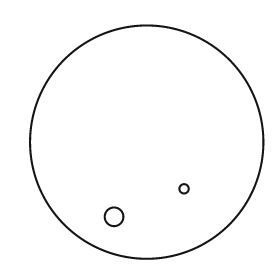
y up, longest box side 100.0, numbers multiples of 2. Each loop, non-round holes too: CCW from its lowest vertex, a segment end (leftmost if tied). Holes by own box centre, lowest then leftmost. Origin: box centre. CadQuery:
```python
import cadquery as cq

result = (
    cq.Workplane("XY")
    .moveTo(0.0, 0.0)
    .circle(50.0)
    .moveTo(-14.0, -32.0)
    .circle(4.0)
    .moveTo(16.0, -20.0)
    .circle(2.0)
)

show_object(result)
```